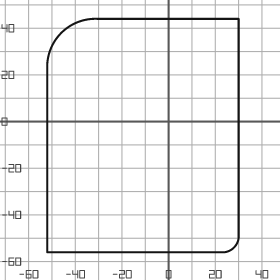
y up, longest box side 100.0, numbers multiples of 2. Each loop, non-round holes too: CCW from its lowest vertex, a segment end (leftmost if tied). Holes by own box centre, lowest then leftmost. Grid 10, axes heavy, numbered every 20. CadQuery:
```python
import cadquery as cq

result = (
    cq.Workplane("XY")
    .moveTo(-52.0, -56.0)
    .lineTo(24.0, -56.0)
    .threePointArc((28.0, -54.0), (30.0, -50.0))
    .lineTo(30.0, 44.0)
    .lineTo(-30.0, 44.0)
    .threePointArc((-46.0, 38.0), (-52.0, 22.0))
    .close()
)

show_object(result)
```